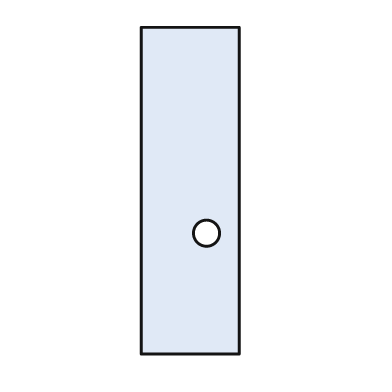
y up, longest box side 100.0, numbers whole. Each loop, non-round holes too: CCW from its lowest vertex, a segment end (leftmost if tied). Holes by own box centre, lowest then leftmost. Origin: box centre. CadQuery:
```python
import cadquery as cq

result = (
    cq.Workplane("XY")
    .moveTo(-15.0, -50.0)
    .lineTo(15.0, -50.0)
    .lineTo(15.0, 50.0)
    .lineTo(-15.0, 50.0)
    .close()
    .moveTo(5.0, -13.0)
    .circle(4.0)
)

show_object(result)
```